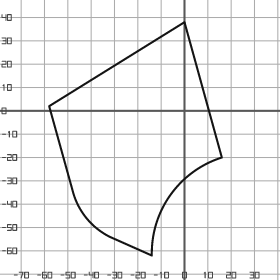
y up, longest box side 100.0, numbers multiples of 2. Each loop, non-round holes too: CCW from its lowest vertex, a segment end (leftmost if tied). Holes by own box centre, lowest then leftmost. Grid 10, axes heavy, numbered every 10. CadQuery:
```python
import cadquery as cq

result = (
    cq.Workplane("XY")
    .moveTo(-14.0, -62.0)
    .threePointArc((-6.0, -36.0), (16.0, -20.0))
    .lineTo(0.0, 38.0)
    .lineTo(-58.0, 2.0)
    .lineTo(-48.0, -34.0)
    .threePointArc((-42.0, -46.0), (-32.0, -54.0))
    .close()
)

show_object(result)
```